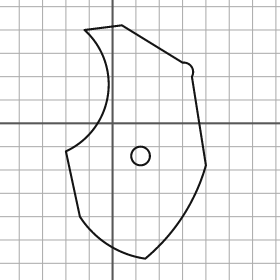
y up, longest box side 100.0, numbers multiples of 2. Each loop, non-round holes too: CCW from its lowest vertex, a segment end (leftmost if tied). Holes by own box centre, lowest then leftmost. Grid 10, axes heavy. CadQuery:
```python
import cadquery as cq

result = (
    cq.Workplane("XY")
    .moveTo(14.0, -58.0)
    .threePointArc((30.0, -40.0), (40.0, -18.0))
    .lineTo(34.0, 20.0)
    .threePointArc((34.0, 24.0), (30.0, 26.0))
    .lineTo(4.0, 42.0)
    .lineTo(-12.0, 40.0)
    .threePointArc((-2.0, 12.0), (-20.0, -12.0))
    .lineTo(-14.0, -40.0)
    .threePointArc((-2.0, -52.0), (14.0, -58.0))
    .close()
    .moveTo(12.0, -14.0)
    .circle(4.0)
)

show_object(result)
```